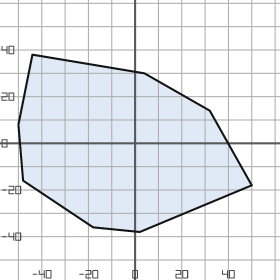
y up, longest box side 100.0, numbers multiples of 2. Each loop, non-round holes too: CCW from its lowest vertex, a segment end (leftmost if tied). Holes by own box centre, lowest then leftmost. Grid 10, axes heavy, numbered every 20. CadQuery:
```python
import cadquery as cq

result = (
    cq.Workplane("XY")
    .moveTo(2.0, -38.0)
    .lineTo(50.0, -18.0)
    .lineTo(32.0, 14.0)
    .lineTo(4.0, 30.0)
    .lineTo(-44.0, 38.0)
    .lineTo(-50.0, 8.0)
    .lineTo(-48.0, -16.0)
    .lineTo(-18.0, -36.0)
    .close()
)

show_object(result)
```